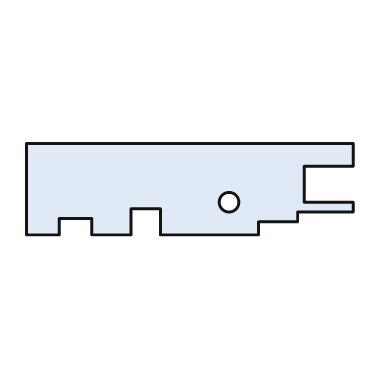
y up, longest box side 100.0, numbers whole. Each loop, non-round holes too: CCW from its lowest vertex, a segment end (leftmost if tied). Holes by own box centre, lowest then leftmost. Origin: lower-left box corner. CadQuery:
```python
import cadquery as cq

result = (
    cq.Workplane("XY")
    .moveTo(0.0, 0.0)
    .lineTo(10.0, 0.0)
    .lineTo(10.0, 5.0)
    .lineTo(20.0, 5.0)
    .lineTo(20.0, 0.0)
    .lineTo(32.0, 0.0)
    .lineTo(32.0, 8.0)
    .lineTo(41.0, 8.0)
    .lineTo(41.0, 0.0)
    .lineTo(71.0, 0.0)
    .lineTo(71.0, 4.0)
    .lineTo(83.0, 4.0)
    .lineTo(83.0, 7.0)
    .lineTo(100.0, 7.0)
    .lineTo(100.0, 10.0)
    .lineTo(85.0, 10.0)
    .lineTo(85.0, 21.0)
    .lineTo(100.0, 21.0)
    .lineTo(100.0, 28.0)
    .lineTo(0.0, 28.0)
    .close()
    .moveTo(62.0, 10.0)
    .circle(3.0)
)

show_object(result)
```